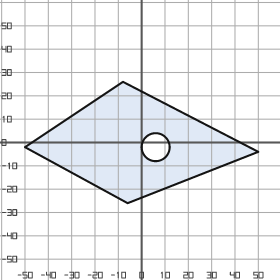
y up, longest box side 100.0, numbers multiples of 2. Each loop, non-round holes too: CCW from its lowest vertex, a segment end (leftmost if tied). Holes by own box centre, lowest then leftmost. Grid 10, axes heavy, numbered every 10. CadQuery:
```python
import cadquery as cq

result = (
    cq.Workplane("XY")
    .moveTo(-6.0, -26.0)
    .lineTo(50.0, -4.0)
    .lineTo(-8.0, 26.0)
    .lineTo(-50.0, -2.0)
    .close()
    .moveTo(6.0, -2.0)
    .circle(6.0)
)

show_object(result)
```